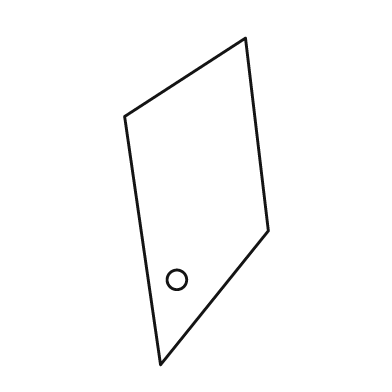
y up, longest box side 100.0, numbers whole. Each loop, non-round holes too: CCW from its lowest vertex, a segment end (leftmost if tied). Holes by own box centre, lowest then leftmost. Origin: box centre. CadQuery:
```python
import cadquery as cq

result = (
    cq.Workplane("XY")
    .moveTo(-11.0, -50.0)
    .lineTo(22.0, -9.0)
    .lineTo(15.0, 50.0)
    .lineTo(-22.0, 26.0)
    .close()
    .moveTo(-6.0, -24.0)
    .circle(3.0)
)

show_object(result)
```